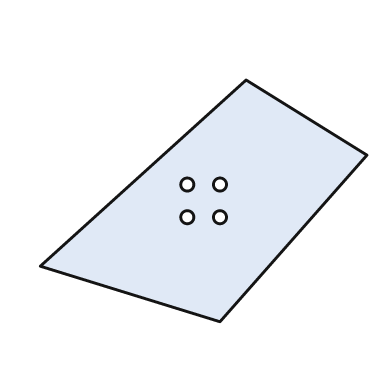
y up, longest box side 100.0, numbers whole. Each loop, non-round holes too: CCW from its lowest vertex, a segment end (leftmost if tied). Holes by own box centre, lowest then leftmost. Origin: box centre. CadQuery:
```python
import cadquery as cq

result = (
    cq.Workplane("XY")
    .moveTo(5.0, -37.0)
    .lineTo(50.0, 14.0)
    .lineTo(13.0, 37.0)
    .lineTo(-50.0, -20.0)
    .close()
    .moveTo(-5.0, -5.0)
    .circle(2.0)
    .moveTo(5.0, -5.0)
    .circle(2.0)
    .moveTo(-5.0, 5.0)
    .circle(2.0)
    .moveTo(5.0, 5.0)
    .circle(2.0)
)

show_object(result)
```